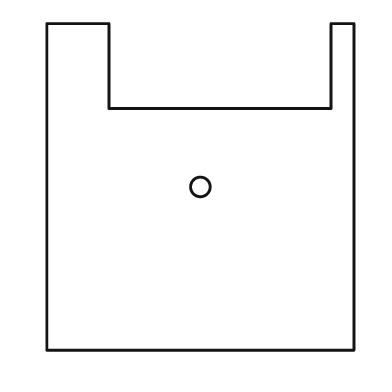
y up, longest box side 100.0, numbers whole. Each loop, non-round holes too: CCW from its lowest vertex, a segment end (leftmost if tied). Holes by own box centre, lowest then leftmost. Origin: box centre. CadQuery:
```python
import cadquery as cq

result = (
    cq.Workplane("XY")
    .moveTo(-47.0, -50.0)
    .lineTo(47.0, -50.0)
    .lineTo(47.0, 50.0)
    .lineTo(40.0, 50.0)
    .lineTo(40.0, 24.0)
    .lineTo(-28.0, 24.0)
    .lineTo(-28.0, 50.0)
    .lineTo(-47.0, 50.0)
    .close()
    .moveTo(0.0, 0.0)
    .circle(3.0)
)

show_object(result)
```